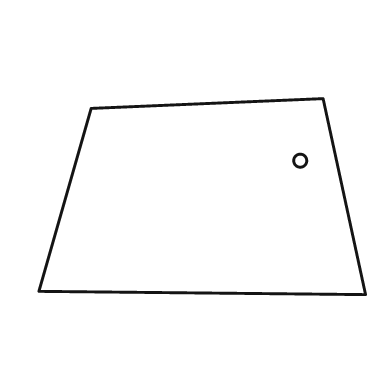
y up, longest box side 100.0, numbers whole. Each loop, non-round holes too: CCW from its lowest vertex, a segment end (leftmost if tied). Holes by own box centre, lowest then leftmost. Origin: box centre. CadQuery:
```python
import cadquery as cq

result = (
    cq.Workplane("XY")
    .moveTo(50.0, -30.0)
    .lineTo(37.0, 30.0)
    .lineTo(-34.0, 27.0)
    .lineTo(-50.0, -29.0)
    .close()
    .moveTo(30.0, 11.0)
    .circle(2.0)
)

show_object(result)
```